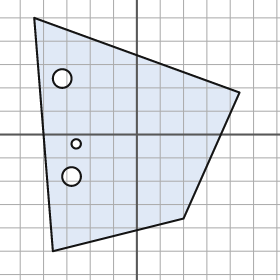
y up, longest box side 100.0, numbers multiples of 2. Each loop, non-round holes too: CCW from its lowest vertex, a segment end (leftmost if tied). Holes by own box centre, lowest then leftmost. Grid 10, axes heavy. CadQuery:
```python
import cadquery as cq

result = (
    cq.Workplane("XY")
    .moveTo(-36.0, -50.0)
    .lineTo(20.0, -36.0)
    .lineTo(44.0, 18.0)
    .lineTo(-44.0, 50.0)
    .close()
    .moveTo(-28.0, -18.0)
    .circle(4.0)
    .moveTo(-26.0, -4.0)
    .circle(2.0)
    .moveTo(-32.0, 24.0)
    .circle(4.0)
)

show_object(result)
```